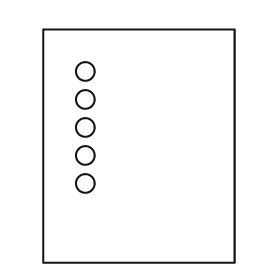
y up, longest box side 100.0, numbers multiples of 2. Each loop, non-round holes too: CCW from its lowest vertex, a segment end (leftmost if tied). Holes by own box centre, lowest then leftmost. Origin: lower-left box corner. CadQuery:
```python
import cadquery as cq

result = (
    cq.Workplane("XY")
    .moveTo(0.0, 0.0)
    .lineTo(82.0, 0.0)
    .lineTo(82.0, 100.0)
    .lineTo(0.0, 100.0)
    .close()
    .moveTo(18.0, 34.0)
    .circle(4.0)
    .moveTo(18.0, 46.0)
    .circle(4.0)
    .moveTo(18.0, 58.0)
    .circle(4.0)
    .moveTo(18.0, 70.0)
    .circle(4.0)
    .moveTo(18.0, 82.0)
    .circle(4.0)
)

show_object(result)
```